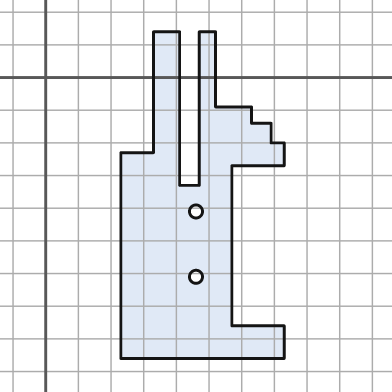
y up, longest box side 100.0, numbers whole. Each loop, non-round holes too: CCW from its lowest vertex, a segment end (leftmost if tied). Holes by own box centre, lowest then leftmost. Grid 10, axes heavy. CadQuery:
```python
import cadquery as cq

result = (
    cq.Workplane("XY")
    .moveTo(23.0, -86.0)
    .lineTo(73.0, -86.0)
    .lineTo(73.0, -76.0)
    .lineTo(57.0, -76.0)
    .lineTo(57.0, -27.0)
    .lineTo(73.0, -27.0)
    .lineTo(73.0, -20.0)
    .lineTo(69.0, -20.0)
    .lineTo(69.0, -14.0)
    .lineTo(63.0, -14.0)
    .lineTo(63.0, -9.0)
    .lineTo(52.0, -9.0)
    .lineTo(52.0, 14.0)
    .lineTo(47.0, 14.0)
    .lineTo(47.0, -33.0)
    .lineTo(41.0, -33.0)
    .lineTo(41.0, 14.0)
    .lineTo(33.0, 14.0)
    .lineTo(33.0, -23.0)
    .lineTo(23.0, -23.0)
    .close()
    .moveTo(46.0, -61.0)
    .circle(2.0)
    .moveTo(46.0, -41.0)
    .circle(2.0)
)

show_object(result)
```